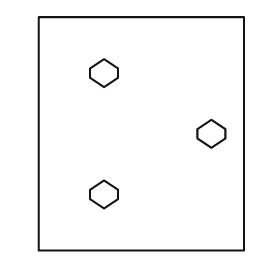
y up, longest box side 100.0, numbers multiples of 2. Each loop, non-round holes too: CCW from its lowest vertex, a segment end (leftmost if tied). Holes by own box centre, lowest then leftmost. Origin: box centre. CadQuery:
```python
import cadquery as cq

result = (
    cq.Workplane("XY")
    .moveTo(-44.0, -50.0)
    .lineTo(44.0, -50.0)
    .lineTo(44.0, 50.0)
    .lineTo(-44.0, 50.0)
    .close()
    .moveTo(-16.0, -32.0)
    .lineTo(-10.0, -28.0)
    .lineTo(-10.0, -24.0)
    .lineTo(-16.0, -20.0)
    .lineTo(-22.0, -24.0)
    .lineTo(-22.0, -28.0)
    .close()
    .moveTo(30.0, -6.0)
    .lineTo(36.0, -2.0)
    .lineTo(36.0, 2.0)
    .lineTo(30.0, 6.0)
    .lineTo(24.0, 2.0)
    .lineTo(24.0, -2.0)
    .close()
    .moveTo(-16.0, 20.0)
    .lineTo(-10.0, 24.0)
    .lineTo(-10.0, 28.0)
    .lineTo(-16.0, 32.0)
    .lineTo(-22.0, 28.0)
    .lineTo(-22.0, 24.0)
    .close()
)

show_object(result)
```